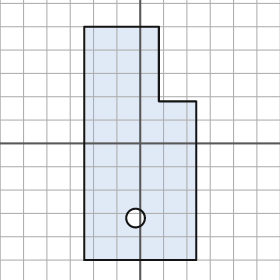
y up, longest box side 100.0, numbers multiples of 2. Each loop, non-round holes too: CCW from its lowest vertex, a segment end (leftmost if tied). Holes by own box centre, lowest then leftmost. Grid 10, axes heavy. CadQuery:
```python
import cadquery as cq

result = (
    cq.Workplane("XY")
    .moveTo(-24.0, -50.0)
    .lineTo(24.0, -50.0)
    .lineTo(24.0, 18.0)
    .lineTo(8.0, 18.0)
    .lineTo(8.0, 50.0)
    .lineTo(-24.0, 50.0)
    .close()
    .moveTo(-2.0, -32.0)
    .circle(4.0)
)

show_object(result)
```